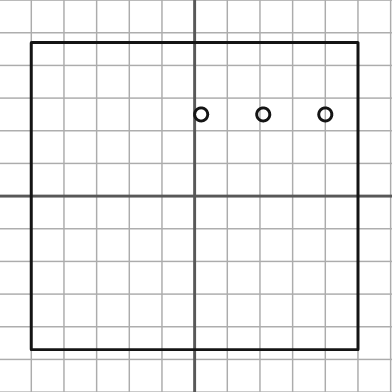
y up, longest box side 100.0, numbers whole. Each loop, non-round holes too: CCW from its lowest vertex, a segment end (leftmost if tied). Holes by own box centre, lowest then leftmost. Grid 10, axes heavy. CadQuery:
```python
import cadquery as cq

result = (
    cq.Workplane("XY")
    .moveTo(-50.0, -47.0)
    .lineTo(50.0, -47.0)
    .lineTo(50.0, 47.0)
    .lineTo(-50.0, 47.0)
    .close()
    .moveTo(2.0, 25.0)
    .circle(2.0)
    .moveTo(21.0, 25.0)
    .circle(2.0)
    .moveTo(40.0, 25.0)
    .circle(2.0)
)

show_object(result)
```